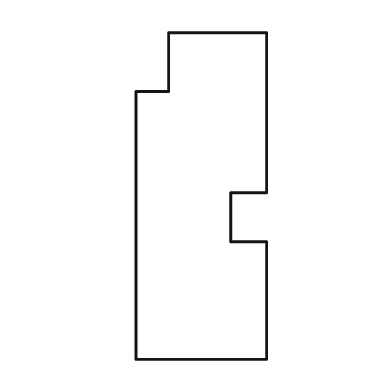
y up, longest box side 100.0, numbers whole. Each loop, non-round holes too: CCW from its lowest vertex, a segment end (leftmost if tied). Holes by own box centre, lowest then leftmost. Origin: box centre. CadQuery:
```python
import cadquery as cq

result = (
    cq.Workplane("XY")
    .moveTo(-20.0, -50.0)
    .lineTo(20.0, -50.0)
    .lineTo(20.0, -14.0)
    .lineTo(9.0, -14.0)
    .lineTo(9.0, 1.0)
    .lineTo(20.0, 1.0)
    .lineTo(20.0, 50.0)
    .lineTo(-10.0, 50.0)
    .lineTo(-10.0, 32.0)
    .lineTo(-20.0, 32.0)
    .close()
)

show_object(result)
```